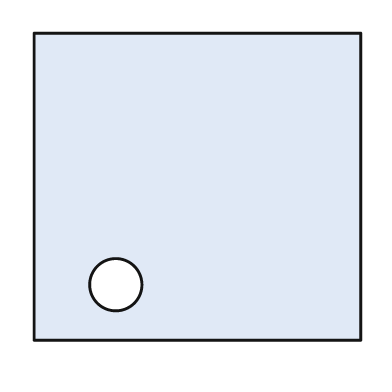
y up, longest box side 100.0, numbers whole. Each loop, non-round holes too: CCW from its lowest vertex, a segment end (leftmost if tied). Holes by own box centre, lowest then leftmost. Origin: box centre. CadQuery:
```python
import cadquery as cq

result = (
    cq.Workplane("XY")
    .moveTo(-50.0, -47.0)
    .lineTo(50.0, -47.0)
    .lineTo(50.0, 47.0)
    .lineTo(-50.0, 47.0)
    .close()
    .moveTo(-25.0, -30.0)
    .circle(8.0)
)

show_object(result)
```